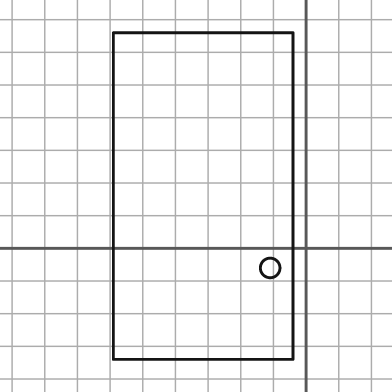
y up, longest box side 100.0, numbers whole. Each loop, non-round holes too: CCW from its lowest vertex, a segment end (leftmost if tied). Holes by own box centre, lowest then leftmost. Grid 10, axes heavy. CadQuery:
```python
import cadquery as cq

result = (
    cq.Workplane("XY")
    .moveTo(-59.0, -34.0)
    .lineTo(-4.0, -34.0)
    .lineTo(-4.0, 66.0)
    .lineTo(-59.0, 66.0)
    .close()
    .moveTo(-11.0, -6.0)
    .circle(3.0)
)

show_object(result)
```